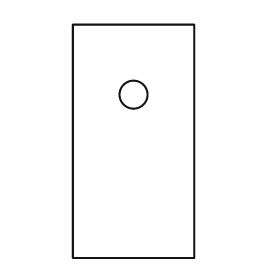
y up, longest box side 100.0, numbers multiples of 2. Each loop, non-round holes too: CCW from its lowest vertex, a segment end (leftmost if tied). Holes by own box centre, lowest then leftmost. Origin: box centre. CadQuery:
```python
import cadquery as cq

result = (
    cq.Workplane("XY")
    .moveTo(-26.0, -50.0)
    .lineTo(26.0, -50.0)
    .lineTo(26.0, 50.0)
    .lineTo(-26.0, 50.0)
    .close()
    .moveTo(0.0, 20.0)
    .circle(6.0)
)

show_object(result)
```